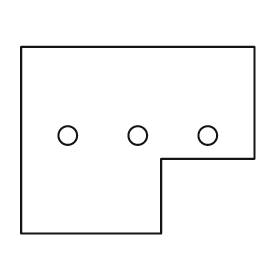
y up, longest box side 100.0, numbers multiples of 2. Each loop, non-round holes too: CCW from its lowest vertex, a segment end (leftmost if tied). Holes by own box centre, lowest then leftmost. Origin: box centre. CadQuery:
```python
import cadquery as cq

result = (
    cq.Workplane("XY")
    .moveTo(-50.0, -40.0)
    .lineTo(10.0, -40.0)
    .lineTo(10.0, -8.0)
    .lineTo(50.0, -8.0)
    .lineTo(50.0, 40.0)
    .lineTo(-50.0, 40.0)
    .close()
    .moveTo(-30.0, 2.0)
    .circle(4.0)
    .moveTo(0.0, 2.0)
    .circle(4.0)
    .moveTo(30.0, 2.0)
    .circle(4.0)
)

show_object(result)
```